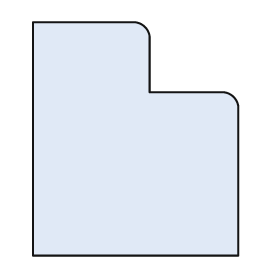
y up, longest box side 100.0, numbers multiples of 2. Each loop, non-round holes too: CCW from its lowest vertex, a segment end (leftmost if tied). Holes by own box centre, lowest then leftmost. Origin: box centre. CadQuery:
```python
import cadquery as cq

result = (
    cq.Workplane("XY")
    .moveTo(-44.0, -50.0)
    .lineTo(44.0, -50.0)
    .lineTo(44.0, 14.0)
    .threePointArc((42.0, 18.0), (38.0, 20.0))
    .lineTo(6.0, 20.0)
    .lineTo(6.0, 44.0)
    .threePointArc((4.0, 48.0), (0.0, 50.0))
    .lineTo(-44.0, 50.0)
    .close()
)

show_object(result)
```